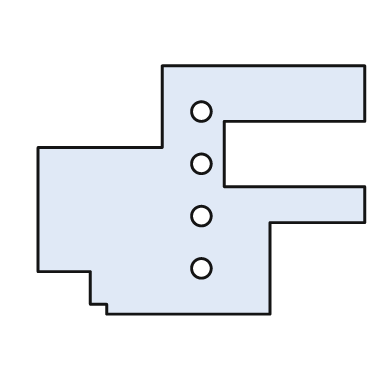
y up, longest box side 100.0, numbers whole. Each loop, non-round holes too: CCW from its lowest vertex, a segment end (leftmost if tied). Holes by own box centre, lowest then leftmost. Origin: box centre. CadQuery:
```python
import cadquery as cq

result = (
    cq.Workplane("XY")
    .moveTo(-29.0, -38.0)
    .lineTo(21.0, -38.0)
    .lineTo(21.0, -10.0)
    .lineTo(50.0, -10.0)
    .lineTo(50.0, 1.0)
    .lineTo(7.0, 1.0)
    .lineTo(7.0, 21.0)
    .lineTo(50.0, 21.0)
    .lineTo(50.0, 38.0)
    .lineTo(-12.0, 38.0)
    .lineTo(-12.0, 13.0)
    .lineTo(-50.0, 13.0)
    .lineTo(-50.0, -25.0)
    .lineTo(-34.0, -25.0)
    .lineTo(-34.0, -35.0)
    .lineTo(-29.0, -35.0)
    .close()
    .moveTo(0.0, -24.0)
    .circle(3.0)
    .moveTo(0.0, -8.0)
    .circle(3.0)
    .moveTo(0.0, 8.0)
    .circle(3.0)
    .moveTo(0.0, 24.0)
    .circle(3.0)
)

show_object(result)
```